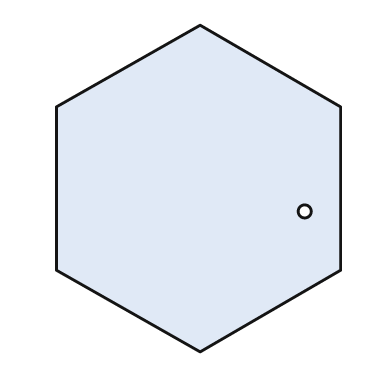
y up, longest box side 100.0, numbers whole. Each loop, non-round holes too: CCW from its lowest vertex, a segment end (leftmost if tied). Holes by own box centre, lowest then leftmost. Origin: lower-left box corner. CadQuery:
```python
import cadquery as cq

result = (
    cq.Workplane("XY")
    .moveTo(44.0, 0.0)
    .lineTo(87.0, 25.0)
    .lineTo(87.0, 75.0)
    .lineTo(44.0, 100.0)
    .lineTo(0.0, 75.0)
    .lineTo(0.0, 25.0)
    .close()
    .moveTo(76.0, 43.0)
    .circle(2.0)
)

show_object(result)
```